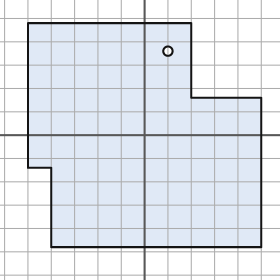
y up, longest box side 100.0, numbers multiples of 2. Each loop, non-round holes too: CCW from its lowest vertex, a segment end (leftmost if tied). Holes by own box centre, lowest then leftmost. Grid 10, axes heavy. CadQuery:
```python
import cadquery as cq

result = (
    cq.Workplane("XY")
    .moveTo(-40.0, -48.0)
    .lineTo(50.0, -48.0)
    .lineTo(50.0, 16.0)
    .lineTo(20.0, 16.0)
    .lineTo(20.0, 48.0)
    .lineTo(-50.0, 48.0)
    .lineTo(-50.0, -14.0)
    .lineTo(-40.0, -14.0)
    .close()
    .moveTo(10.0, 36.0)
    .circle(2.0)
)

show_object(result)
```